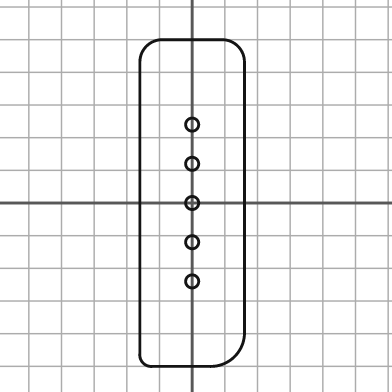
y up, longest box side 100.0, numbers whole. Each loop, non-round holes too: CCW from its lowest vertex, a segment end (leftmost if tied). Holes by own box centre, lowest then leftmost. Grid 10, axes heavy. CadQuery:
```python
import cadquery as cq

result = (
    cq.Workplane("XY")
    .moveTo(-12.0, -50.0)
    .lineTo(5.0, -50.0)
    .threePointArc((13.0, -47.0), (16.0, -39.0))
    .lineTo(16.0, 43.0)
    .threePointArc((14.0, 48.0), (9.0, 50.0))
    .lineTo(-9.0, 50.0)
    .threePointArc((-14.0, 48.0), (-16.0, 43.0))
    .lineTo(-16.0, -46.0)
    .threePointArc((-15.0, -49.0), (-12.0, -50.0))
    .close()
    .moveTo(0.0, -24.0)
    .circle(2.0)
    .moveTo(0.0, -12.0)
    .circle(2.0)
    .moveTo(0.0, 0.0)
    .circle(2.0)
    .moveTo(0.0, 12.0)
    .circle(2.0)
    .moveTo(0.0, 24.0)
    .circle(2.0)
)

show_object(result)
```